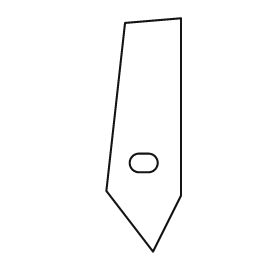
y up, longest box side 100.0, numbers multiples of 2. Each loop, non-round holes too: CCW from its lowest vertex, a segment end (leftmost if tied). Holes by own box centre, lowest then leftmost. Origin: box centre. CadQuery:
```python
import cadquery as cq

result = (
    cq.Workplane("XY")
    .moveTo(4.0, -50.0)
    .lineTo(16.0, -26.0)
    .lineTo(16.0, 50.0)
    .lineTo(-8.0, 48.0)
    .lineTo(-16.0, -24.0)
    .close()
    .moveTo(-2.0, -16.0)
    .lineTo(2.0, -16.0)
    .threePointArc((6.0, -12.0), (2.0, -8.0))
    .lineTo(-2.0, -8.0)
    .threePointArc((-6.0, -12.0), (-2.0, -16.0))
    .close()
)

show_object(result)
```